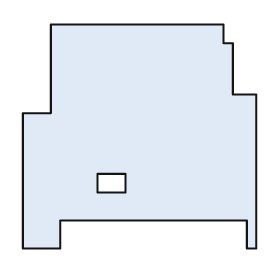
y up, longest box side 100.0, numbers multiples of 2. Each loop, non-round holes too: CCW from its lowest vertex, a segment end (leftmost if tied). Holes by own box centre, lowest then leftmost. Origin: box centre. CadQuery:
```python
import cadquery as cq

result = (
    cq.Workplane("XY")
    .moveTo(-50.0, -48.0)
    .lineTo(-34.0, -48.0)
    .lineTo(-34.0, -36.0)
    .lineTo(46.0, -36.0)
    .lineTo(46.0, -48.0)
    .lineTo(50.0, -48.0)
    .lineTo(50.0, 18.0)
    .lineTo(40.0, 18.0)
    .lineTo(40.0, 40.0)
    .lineTo(36.0, 40.0)
    .lineTo(36.0, 48.0)
    .lineTo(-38.0, 48.0)
    .lineTo(-38.0, 10.0)
    .lineTo(-50.0, 10.0)
    .close()
    .moveTo(-18.0, -24.0)
    .lineTo(-6.0, -24.0)
    .lineTo(-6.0, -16.0)
    .lineTo(-18.0, -16.0)
    .close()
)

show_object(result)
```